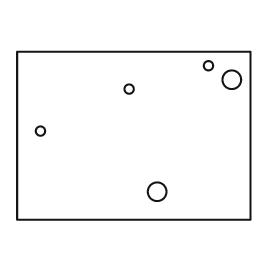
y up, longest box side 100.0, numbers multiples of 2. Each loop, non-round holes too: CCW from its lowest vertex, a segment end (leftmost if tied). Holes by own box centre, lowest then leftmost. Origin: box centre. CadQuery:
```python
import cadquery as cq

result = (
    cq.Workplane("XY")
    .moveTo(-50.0, -36.0)
    .lineTo(50.0, -36.0)
    .lineTo(50.0, 36.0)
    .lineTo(-50.0, 36.0)
    .close()
    .moveTo(10.0, -24.0)
    .circle(4.0)
    .moveTo(-40.0, 2.0)
    .circle(2.0)
    .moveTo(-2.0, 20.0)
    .circle(2.0)
    .moveTo(42.0, 24.0)
    .circle(4.0)
    .moveTo(32.0, 30.0)
    .circle(2.0)
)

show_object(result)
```